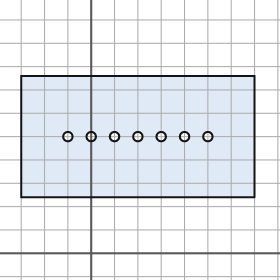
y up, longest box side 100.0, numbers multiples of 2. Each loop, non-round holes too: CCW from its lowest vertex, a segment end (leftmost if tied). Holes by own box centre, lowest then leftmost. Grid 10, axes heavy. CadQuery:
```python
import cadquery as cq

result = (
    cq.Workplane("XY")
    .moveTo(-30.0, 24.0)
    .lineTo(70.0, 24.0)
    .lineTo(70.0, 76.0)
    .lineTo(-30.0, 76.0)
    .close()
    .moveTo(-10.0, 50.0)
    .circle(2.0)
    .moveTo(0.0, 50.0)
    .circle(2.0)
    .moveTo(10.0, 50.0)
    .circle(2.0)
    .moveTo(20.0, 50.0)
    .circle(2.0)
    .moveTo(30.0, 50.0)
    .circle(2.0)
    .moveTo(40.0, 50.0)
    .circle(2.0)
    .moveTo(50.0, 50.0)
    .circle(2.0)
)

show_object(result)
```